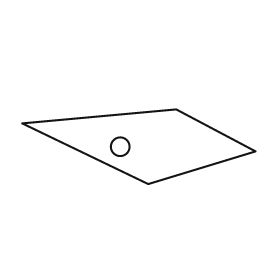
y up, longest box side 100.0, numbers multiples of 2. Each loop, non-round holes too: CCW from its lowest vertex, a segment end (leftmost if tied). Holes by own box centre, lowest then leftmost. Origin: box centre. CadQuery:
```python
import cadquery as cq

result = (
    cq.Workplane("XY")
    .moveTo(4.0, -16.0)
    .lineTo(50.0, -2.0)
    .lineTo(16.0, 16.0)
    .lineTo(-50.0, 10.0)
    .close()
    .moveTo(-8.0, 0.0)
    .circle(4.0)
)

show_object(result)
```